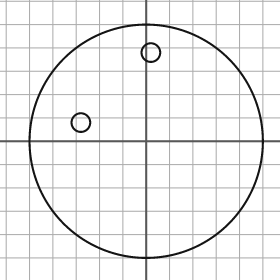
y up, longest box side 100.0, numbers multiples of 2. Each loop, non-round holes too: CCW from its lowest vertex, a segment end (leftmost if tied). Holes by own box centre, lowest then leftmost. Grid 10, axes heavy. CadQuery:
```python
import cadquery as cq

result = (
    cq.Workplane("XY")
    .moveTo(0.0, 0.0)
    .circle(50.0)
    .moveTo(-28.0, 8.0)
    .circle(4.0)
    .moveTo(2.0, 38.0)
    .circle(4.0)
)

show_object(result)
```